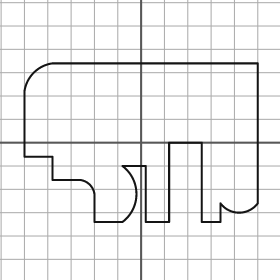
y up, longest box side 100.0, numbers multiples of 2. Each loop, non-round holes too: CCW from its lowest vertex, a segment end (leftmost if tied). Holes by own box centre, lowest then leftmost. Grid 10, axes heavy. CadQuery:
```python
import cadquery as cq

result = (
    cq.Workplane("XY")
    .moveTo(-20.0, -34.0)
    .lineTo(-8.0, -34.0)
    .threePointArc((-2.0, -22.0), (-8.0, -10.0))
    .lineTo(2.0, -10.0)
    .lineTo(2.0, -34.0)
    .lineTo(12.0, -34.0)
    .lineTo(12.0, 0.0)
    .lineTo(26.0, 0.0)
    .lineTo(26.0, -34.0)
    .lineTo(34.0, -34.0)
    .lineTo(34.0, -26.0)
    .threePointArc((42.0, -30.0), (50.0, -26.0))
    .lineTo(50.0, 34.0)
    .lineTo(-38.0, 34.0)
    .threePointArc((-46.0, 30.0), (-50.0, 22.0))
    .lineTo(-50.0, -6.0)
    .lineTo(-38.0, -6.0)
    .lineTo(-38.0, -16.0)
    .lineTo(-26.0, -16.0)
    .threePointArc((-22.0, -18.0), (-20.0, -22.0))
    .close()
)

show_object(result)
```